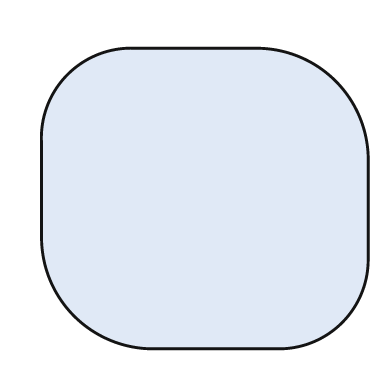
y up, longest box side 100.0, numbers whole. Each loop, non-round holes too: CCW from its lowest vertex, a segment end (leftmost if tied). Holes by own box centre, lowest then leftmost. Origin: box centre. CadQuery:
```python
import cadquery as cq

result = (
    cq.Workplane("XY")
    .moveTo(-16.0, -46.0)
    .lineTo(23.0, -46.0)
    .threePointArc((42.0, -38.0), (50.0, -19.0))
    .lineTo(50.0, 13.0)
    .threePointArc((40.0, 36.0), (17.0, 46.0))
    .lineTo(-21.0, 46.0)
    .threePointArc((-42.0, 38.0), (-50.0, 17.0))
    .lineTo(-50.0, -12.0)
    .threePointArc((-40.0, -36.0), (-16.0, -46.0))
    .close()
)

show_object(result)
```